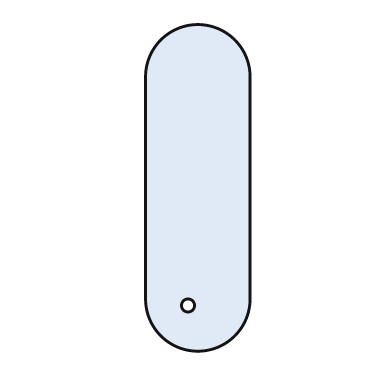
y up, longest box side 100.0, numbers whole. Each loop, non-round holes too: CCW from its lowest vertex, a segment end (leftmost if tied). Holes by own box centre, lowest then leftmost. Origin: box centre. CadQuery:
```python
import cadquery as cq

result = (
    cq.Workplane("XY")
    .moveTo(-16.0, -34.0)
    .threePointArc((0.0, -50.0), (16.0, -34.0))
    .lineTo(16.0, 34.0)
    .threePointArc((0.0, 50.0), (-16.0, 34.0))
    .close()
    .moveTo(-3.0, -36.0)
    .circle(2.0)
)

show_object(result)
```